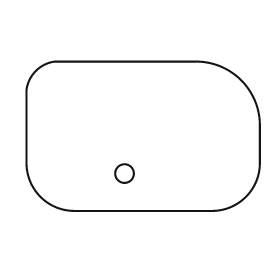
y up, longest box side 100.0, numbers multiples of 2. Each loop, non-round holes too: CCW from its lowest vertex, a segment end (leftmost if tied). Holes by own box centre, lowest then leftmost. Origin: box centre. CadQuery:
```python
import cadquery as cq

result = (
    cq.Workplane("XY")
    .moveTo(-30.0, -32.0)
    .lineTo(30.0, -32.0)
    .threePointArc((44.0, -26.0), (50.0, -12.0))
    .lineTo(50.0, 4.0)
    .threePointArc((42.0, 24.0), (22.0, 32.0))
    .lineTo(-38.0, 32.0)
    .threePointArc((-46.0, 28.0), (-50.0, 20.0))
    .lineTo(-50.0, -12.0)
    .threePointArc((-44.0, -26.0), (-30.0, -32.0))
    .close()
    .moveTo(-8.0, -16.0)
    .circle(4.0)
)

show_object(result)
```